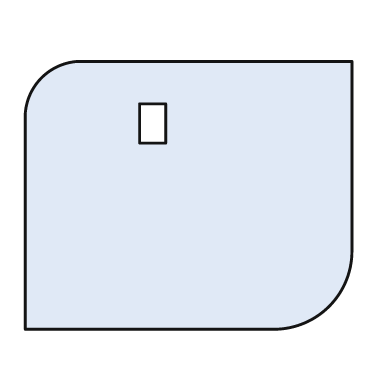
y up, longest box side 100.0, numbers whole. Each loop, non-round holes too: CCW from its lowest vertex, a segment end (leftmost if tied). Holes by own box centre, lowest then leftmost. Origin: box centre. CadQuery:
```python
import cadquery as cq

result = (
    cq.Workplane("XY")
    .moveTo(-50.0, -41.0)
    .lineTo(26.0, -41.0)
    .threePointArc((43.0, -34.0), (50.0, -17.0))
    .lineTo(50.0, 41.0)
    .lineTo(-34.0, 41.0)
    .threePointArc((-45.0, 36.0), (-50.0, 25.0))
    .close()
    .moveTo(-15.0, 16.0)
    .lineTo(-7.0, 16.0)
    .lineTo(-7.0, 28.0)
    .lineTo(-15.0, 28.0)
    .close()
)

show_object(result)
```